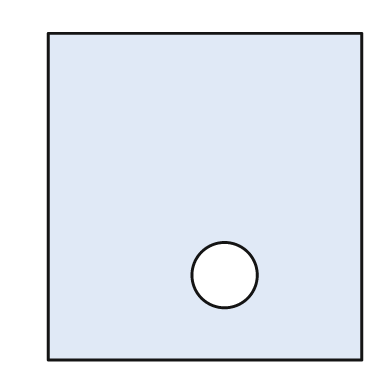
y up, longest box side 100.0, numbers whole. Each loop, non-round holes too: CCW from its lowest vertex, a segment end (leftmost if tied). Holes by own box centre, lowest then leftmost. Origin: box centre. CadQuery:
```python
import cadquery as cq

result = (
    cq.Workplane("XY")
    .moveTo(-48.0, -50.0)
    .lineTo(48.0, -50.0)
    .lineTo(48.0, 50.0)
    .lineTo(-48.0, 50.0)
    .close()
    .moveTo(6.0, -24.0)
    .circle(10.0)
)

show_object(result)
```